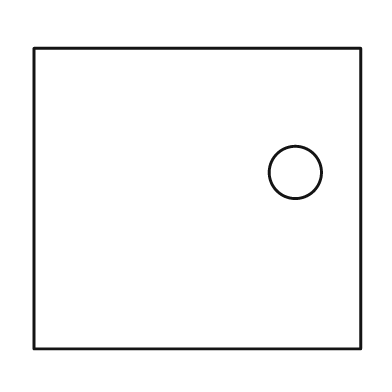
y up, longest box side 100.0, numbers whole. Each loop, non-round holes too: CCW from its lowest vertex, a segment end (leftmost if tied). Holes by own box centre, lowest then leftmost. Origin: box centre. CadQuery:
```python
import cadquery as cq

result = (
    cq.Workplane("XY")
    .moveTo(-50.0, -46.0)
    .lineTo(50.0, -46.0)
    .lineTo(50.0, 46.0)
    .lineTo(-50.0, 46.0)
    .close()
    .moveTo(30.0, 8.0)
    .circle(8.0)
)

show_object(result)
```